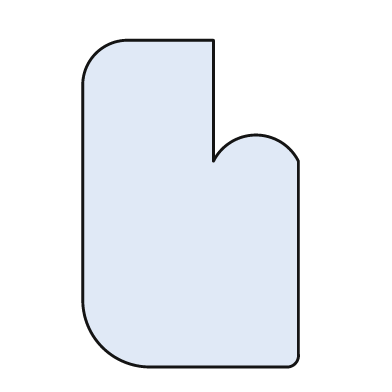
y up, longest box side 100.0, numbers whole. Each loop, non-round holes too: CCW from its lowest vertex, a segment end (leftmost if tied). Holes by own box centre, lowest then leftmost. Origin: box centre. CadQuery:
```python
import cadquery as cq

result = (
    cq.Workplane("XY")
    .moveTo(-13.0, -50.0)
    .lineTo(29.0, -50.0)
    .threePointArc((32.0, -49.0), (33.0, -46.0))
    .lineTo(33.0, 13.0)
    .threePointArc((20.0, 21.0), (7.0, 13.0))
    .lineTo(7.0, 50.0)
    .lineTo(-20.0, 50.0)
    .threePointArc((-29.0, 46.0), (-33.0, 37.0))
    .lineTo(-33.0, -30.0)
    .threePointArc((-27.0, -44.0), (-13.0, -50.0))
    .close()
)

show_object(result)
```